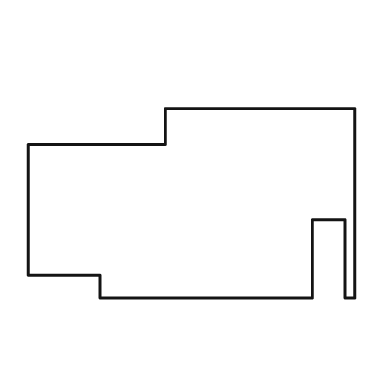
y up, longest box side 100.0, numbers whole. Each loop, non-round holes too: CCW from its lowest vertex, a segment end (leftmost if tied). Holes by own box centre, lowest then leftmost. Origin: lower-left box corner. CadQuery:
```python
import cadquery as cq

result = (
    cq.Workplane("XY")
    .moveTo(22.0, 0.0)
    .lineTo(87.0, 0.0)
    .lineTo(87.0, 24.0)
    .lineTo(97.0, 24.0)
    .lineTo(97.0, 0.0)
    .lineTo(100.0, 0.0)
    .lineTo(100.0, 58.0)
    .lineTo(42.0, 58.0)
    .lineTo(42.0, 47.0)
    .lineTo(0.0, 47.0)
    .lineTo(0.0, 7.0)
    .lineTo(22.0, 7.0)
    .close()
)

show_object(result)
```